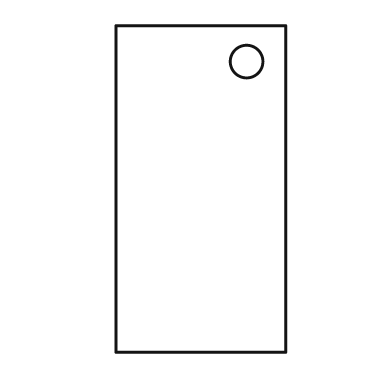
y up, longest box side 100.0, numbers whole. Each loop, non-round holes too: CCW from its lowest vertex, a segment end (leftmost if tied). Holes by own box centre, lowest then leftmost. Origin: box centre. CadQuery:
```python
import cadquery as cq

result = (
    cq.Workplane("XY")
    .moveTo(-26.0, -50.0)
    .lineTo(26.0, -50.0)
    .lineTo(26.0, 50.0)
    .lineTo(-26.0, 50.0)
    .close()
    .moveTo(14.0, 39.0)
    .circle(5.0)
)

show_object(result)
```